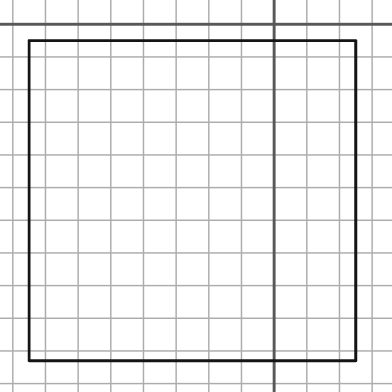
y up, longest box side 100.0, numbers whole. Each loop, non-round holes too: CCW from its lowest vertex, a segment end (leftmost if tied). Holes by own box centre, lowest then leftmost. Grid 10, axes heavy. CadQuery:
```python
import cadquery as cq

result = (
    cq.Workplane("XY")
    .moveTo(-75.0, -103.0)
    .lineTo(25.0, -103.0)
    .lineTo(25.0, -5.0)
    .lineTo(-75.0, -5.0)
    .close()
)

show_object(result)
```